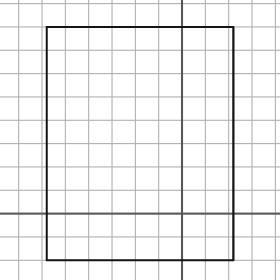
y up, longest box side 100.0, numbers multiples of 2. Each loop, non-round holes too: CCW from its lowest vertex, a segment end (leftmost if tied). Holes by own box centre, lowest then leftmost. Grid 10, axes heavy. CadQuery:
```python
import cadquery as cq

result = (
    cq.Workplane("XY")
    .moveTo(-58.0, -20.0)
    .lineTo(22.0, -20.0)
    .lineTo(22.0, 80.0)
    .lineTo(-58.0, 80.0)
    .close()
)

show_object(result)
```